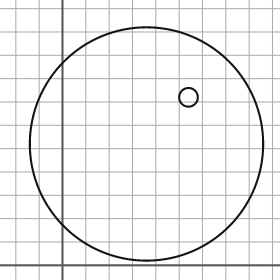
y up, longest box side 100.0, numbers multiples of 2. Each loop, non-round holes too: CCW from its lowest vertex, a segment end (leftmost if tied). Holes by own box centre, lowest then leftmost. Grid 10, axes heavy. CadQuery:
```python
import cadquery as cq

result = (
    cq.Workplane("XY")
    .moveTo(36.0, 52.0)
    .circle(50.0)
    .moveTo(54.0, 72.0)
    .circle(4.0)
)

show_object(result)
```